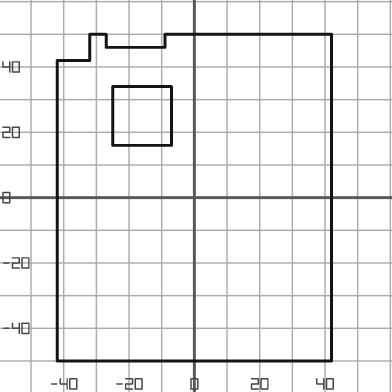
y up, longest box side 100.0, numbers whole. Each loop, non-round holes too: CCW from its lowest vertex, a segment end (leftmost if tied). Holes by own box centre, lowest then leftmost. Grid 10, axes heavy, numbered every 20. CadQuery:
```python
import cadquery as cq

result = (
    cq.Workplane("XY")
    .moveTo(-42.0, -50.0)
    .lineTo(42.0, -50.0)
    .lineTo(42.0, 50.0)
    .lineTo(-9.0, 50.0)
    .lineTo(-9.0, 46.0)
    .lineTo(-27.0, 46.0)
    .lineTo(-27.0, 50.0)
    .lineTo(-32.0, 50.0)
    .lineTo(-32.0, 42.0)
    .lineTo(-42.0, 42.0)
    .close()
    .moveTo(-25.0, 16.0)
    .lineTo(-7.0, 16.0)
    .lineTo(-7.0, 34.0)
    .lineTo(-25.0, 34.0)
    .close()
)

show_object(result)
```